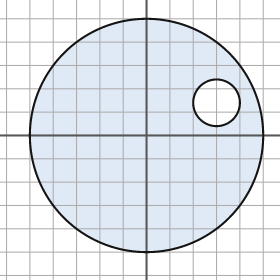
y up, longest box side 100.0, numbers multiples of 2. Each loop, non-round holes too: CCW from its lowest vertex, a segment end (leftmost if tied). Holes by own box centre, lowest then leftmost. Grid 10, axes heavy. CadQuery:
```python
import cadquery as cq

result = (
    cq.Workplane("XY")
    .moveTo(0.0, 0.0)
    .circle(50.0)
    .moveTo(30.0, 14.0)
    .circle(10.0)
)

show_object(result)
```